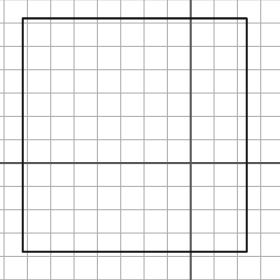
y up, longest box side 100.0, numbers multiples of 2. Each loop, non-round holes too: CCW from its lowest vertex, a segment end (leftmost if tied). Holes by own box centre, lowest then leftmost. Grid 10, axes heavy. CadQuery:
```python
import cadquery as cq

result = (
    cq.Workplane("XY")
    .moveTo(-72.0, -38.0)
    .lineTo(24.0, -38.0)
    .lineTo(24.0, 62.0)
    .lineTo(-72.0, 62.0)
    .close()
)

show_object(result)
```